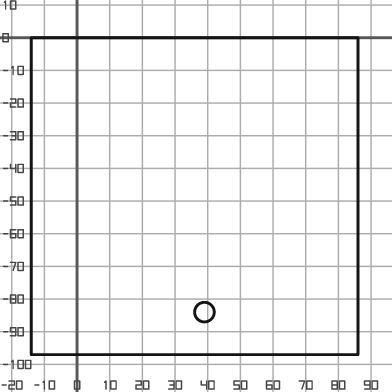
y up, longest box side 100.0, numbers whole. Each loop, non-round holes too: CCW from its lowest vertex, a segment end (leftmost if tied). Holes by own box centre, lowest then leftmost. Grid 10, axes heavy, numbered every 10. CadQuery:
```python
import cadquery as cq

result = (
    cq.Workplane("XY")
    .moveTo(-14.0, -97.0)
    .lineTo(86.0, -97.0)
    .lineTo(86.0, 0.0)
    .lineTo(-14.0, 0.0)
    .close()
    .moveTo(39.0, -84.0)
    .circle(3.0)
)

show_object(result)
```